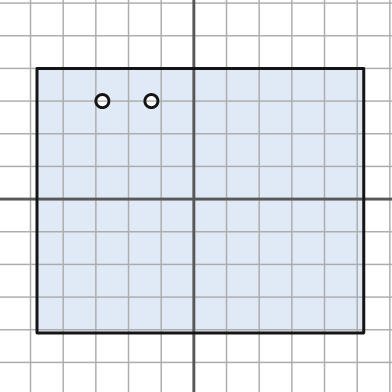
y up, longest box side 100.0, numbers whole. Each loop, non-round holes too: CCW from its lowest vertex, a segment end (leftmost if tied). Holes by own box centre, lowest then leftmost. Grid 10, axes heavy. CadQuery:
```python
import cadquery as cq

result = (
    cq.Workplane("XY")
    .moveTo(-48.0, -41.0)
    .lineTo(52.0, -41.0)
    .lineTo(52.0, 40.0)
    .lineTo(-48.0, 40.0)
    .close()
    .moveTo(-28.0, 30.0)
    .circle(2.0)
    .moveTo(-13.0, 30.0)
    .circle(2.0)
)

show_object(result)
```